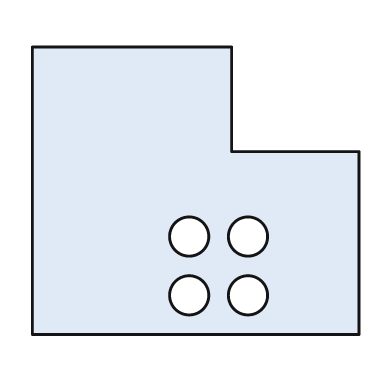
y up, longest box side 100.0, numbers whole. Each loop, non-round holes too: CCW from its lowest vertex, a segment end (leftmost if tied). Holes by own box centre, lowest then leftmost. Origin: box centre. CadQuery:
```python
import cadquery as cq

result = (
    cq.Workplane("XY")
    .moveTo(-50.0, -44.0)
    .lineTo(50.0, -44.0)
    .lineTo(50.0, 12.0)
    .lineTo(11.0, 12.0)
    .lineTo(11.0, 44.0)
    .lineTo(-50.0, 44.0)
    .close()
    .moveTo(-2.0, -32.0)
    .circle(6.0)
    .moveTo(16.0, -32.0)
    .circle(6.0)
    .moveTo(-2.0, -14.0)
    .circle(6.0)
    .moveTo(16.0, -14.0)
    .circle(6.0)
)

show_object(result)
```